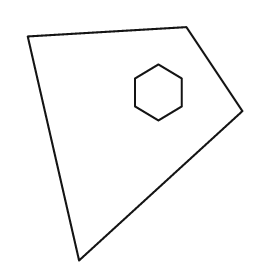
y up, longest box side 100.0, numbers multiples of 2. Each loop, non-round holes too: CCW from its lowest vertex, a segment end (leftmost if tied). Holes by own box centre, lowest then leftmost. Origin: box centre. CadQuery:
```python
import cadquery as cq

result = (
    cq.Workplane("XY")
    .moveTo(-24.0, -50.0)
    .lineTo(46.0, 14.0)
    .lineTo(22.0, 50.0)
    .lineTo(-46.0, 46.0)
    .close()
    .moveTo(10.0, 10.0)
    .lineTo(20.0, 16.0)
    .lineTo(20.0, 28.0)
    .lineTo(10.0, 34.0)
    .lineTo(0.0, 28.0)
    .lineTo(0.0, 16.0)
    .close()
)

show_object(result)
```